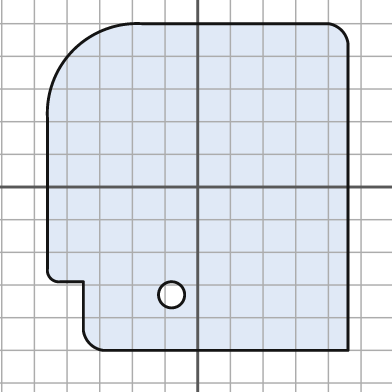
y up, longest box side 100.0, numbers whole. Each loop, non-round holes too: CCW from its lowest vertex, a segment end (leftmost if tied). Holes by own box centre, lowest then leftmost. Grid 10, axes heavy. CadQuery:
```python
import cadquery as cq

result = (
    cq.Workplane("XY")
    .moveTo(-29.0, -50.0)
    .lineTo(46.0, -50.0)
    .lineTo(46.0, 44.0)
    .threePointArc((44.0, 48.0), (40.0, 50.0))
    .lineTo(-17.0, 50.0)
    .threePointArc((-38.0, 42.0), (-46.0, 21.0))
    .lineTo(-46.0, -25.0)
    .threePointArc((-45.0, -28.0), (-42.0, -29.0))
    .lineTo(-35.0, -29.0)
    .lineTo(-35.0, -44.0)
    .threePointArc((-33.0, -48.0), (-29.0, -50.0))
    .close()
    .moveTo(-8.0, -33.0)
    .circle(4.0)
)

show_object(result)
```